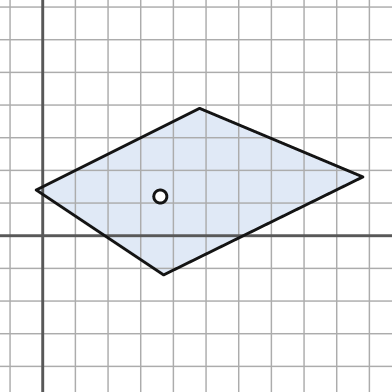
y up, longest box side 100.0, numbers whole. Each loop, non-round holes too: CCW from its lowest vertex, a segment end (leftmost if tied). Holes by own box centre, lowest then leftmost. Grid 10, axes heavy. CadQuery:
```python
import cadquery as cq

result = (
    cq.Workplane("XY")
    .moveTo(37.0, -12.0)
    .lineTo(98.0, 18.0)
    .lineTo(48.0, 39.0)
    .lineTo(-2.0, 14.0)
    .close()
    .moveTo(36.0, 12.0)
    .circle(2.0)
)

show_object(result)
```